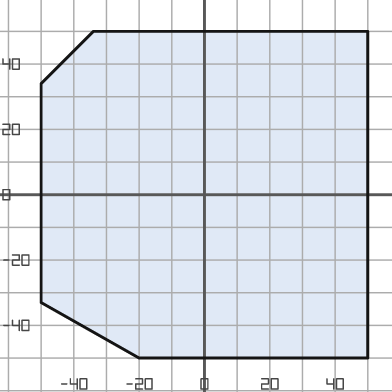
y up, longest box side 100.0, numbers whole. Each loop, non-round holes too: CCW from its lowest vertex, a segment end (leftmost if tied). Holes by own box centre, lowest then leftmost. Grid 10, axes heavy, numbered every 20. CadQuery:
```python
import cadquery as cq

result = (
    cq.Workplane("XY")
    .moveTo(-20.0, -50.0)
    .lineTo(50.0, -50.0)
    .lineTo(50.0, 50.0)
    .lineTo(-34.0, 50.0)
    .lineTo(-50.0, 34.0)
    .lineTo(-50.0, -33.0)
    .close()
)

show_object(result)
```